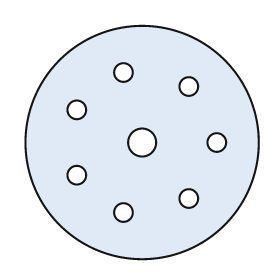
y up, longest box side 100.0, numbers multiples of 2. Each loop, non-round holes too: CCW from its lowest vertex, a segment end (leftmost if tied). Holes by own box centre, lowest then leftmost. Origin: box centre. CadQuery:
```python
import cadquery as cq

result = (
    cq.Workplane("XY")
    .moveTo(0.0, 0.0)
    .circle(50.0)
    .moveTo(-8.0, -30.0)
    .circle(4.0)
    .moveTo(20.0, -24.0)
    .circle(4.0)
    .moveTo(-28.0, -14.0)
    .circle(4.0)
    .moveTo(0.0, 0.0)
    .circle(6.0)
    .moveTo(32.0, 0.0)
    .circle(4.0)
    .moveTo(-28.0, 14.0)
    .circle(4.0)
    .moveTo(20.0, 24.0)
    .circle(4.0)
    .moveTo(-8.0, 30.0)
    .circle(4.0)
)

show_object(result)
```